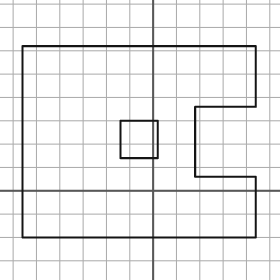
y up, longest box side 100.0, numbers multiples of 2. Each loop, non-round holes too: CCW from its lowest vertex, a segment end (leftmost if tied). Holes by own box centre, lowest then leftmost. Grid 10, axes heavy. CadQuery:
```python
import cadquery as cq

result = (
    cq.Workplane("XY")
    .moveTo(-56.0, -20.0)
    .lineTo(44.0, -20.0)
    .lineTo(44.0, 6.0)
    .lineTo(18.0, 6.0)
    .lineTo(18.0, 36.0)
    .lineTo(44.0, 36.0)
    .lineTo(44.0, 62.0)
    .lineTo(-56.0, 62.0)
    .close()
    .moveTo(-14.0, 14.0)
    .lineTo(2.0, 14.0)
    .lineTo(2.0, 30.0)
    .lineTo(-14.0, 30.0)
    .close()
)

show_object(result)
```